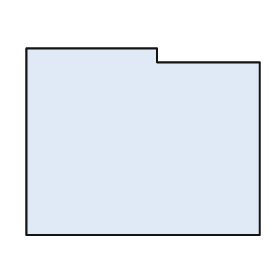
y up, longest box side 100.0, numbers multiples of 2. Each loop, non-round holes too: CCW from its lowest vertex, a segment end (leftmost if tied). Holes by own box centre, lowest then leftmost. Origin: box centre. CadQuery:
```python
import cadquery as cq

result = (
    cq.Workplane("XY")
    .moveTo(-50.0, -40.0)
    .lineTo(50.0, -40.0)
    .lineTo(50.0, 34.0)
    .lineTo(6.0, 34.0)
    .lineTo(6.0, 40.0)
    .lineTo(-50.0, 40.0)
    .close()
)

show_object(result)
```